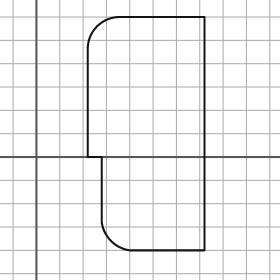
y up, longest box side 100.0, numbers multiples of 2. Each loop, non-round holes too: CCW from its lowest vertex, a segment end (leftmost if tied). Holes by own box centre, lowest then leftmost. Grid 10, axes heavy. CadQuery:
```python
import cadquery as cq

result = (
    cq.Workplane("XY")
    .moveTo(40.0, -40.0)
    .lineTo(72.0, -40.0)
    .lineTo(72.0, 60.0)
    .lineTo(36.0, 60.0)
    .threePointArc((26.0, 56.0), (22.0, 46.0))
    .lineTo(22.0, 0.0)
    .lineTo(28.0, 0.0)
    .lineTo(28.0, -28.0)
    .threePointArc((32.0, -36.0), (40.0, -40.0))
    .close()
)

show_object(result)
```